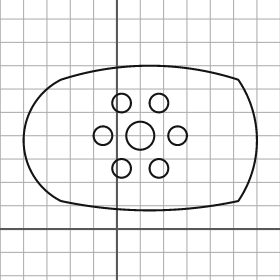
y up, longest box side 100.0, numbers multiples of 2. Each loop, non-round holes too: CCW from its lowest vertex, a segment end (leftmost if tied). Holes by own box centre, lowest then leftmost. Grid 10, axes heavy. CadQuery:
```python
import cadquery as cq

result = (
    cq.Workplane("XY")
    .moveTo(-24.0, 12.0)
    .threePointArc((14.0, 8.0), (52.0, 12.0))
    .threePointArc((60.0, 38.0), (52.0, 64.0))
    .threePointArc((14.0, 70.0), (-24.0, 64.0))
    .threePointArc((-40.0, 38.0), (-24.0, 12.0))
    .close()
    .moveTo(2.0, 26.0)
    .circle(4.0)
    .moveTo(18.0, 26.0)
    .circle(4.0)
    .moveTo(-6.0, 40.0)
    .circle(4.0)
    .moveTo(10.0, 40.0)
    .circle(6.0)
    .moveTo(26.0, 40.0)
    .circle(4.0)
    .moveTo(2.0, 54.0)
    .circle(4.0)
    .moveTo(18.0, 54.0)
    .circle(4.0)
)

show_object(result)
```